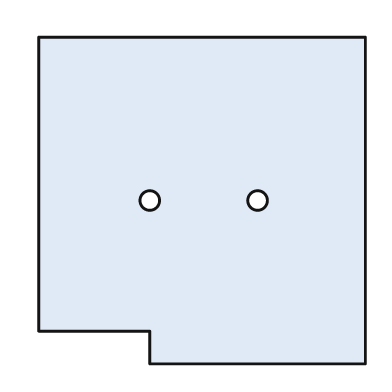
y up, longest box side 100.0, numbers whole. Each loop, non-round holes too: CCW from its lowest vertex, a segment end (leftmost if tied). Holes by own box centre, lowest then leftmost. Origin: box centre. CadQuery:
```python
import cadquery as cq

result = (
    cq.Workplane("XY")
    .moveTo(-16.0, -50.0)
    .lineTo(50.0, -50.0)
    .lineTo(50.0, 50.0)
    .lineTo(-50.0, 50.0)
    .lineTo(-50.0, -40.0)
    .lineTo(-16.0, -40.0)
    .close()
    .moveTo(-16.0, 0.0)
    .circle(3.0)
    .moveTo(17.0, 0.0)
    .circle(3.0)
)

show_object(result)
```